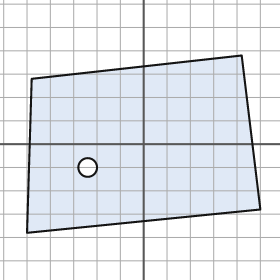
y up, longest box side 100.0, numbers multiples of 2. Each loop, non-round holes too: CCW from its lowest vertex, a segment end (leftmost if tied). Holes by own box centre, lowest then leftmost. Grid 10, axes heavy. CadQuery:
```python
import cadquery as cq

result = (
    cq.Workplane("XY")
    .moveTo(-50.0, -38.0)
    .lineTo(50.0, -28.0)
    .lineTo(42.0, 38.0)
    .lineTo(-48.0, 28.0)
    .close()
    .moveTo(-24.0, -10.0)
    .circle(4.0)
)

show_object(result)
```